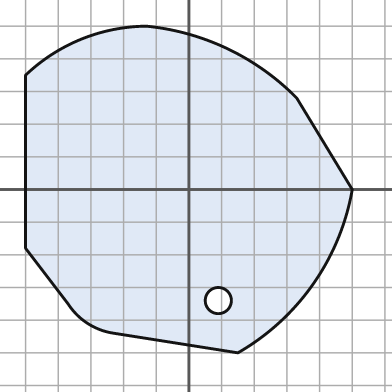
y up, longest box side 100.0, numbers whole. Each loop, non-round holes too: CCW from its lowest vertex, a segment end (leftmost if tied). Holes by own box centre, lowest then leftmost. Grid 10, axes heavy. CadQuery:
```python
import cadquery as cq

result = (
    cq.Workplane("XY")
    .moveTo(15.0, -50.0)
    .threePointArc((38.0, -29.0), (50.0, 0.0))
    .lineTo(33.0, 28.0)
    .threePointArc((12.0, 43.0), (-13.0, 50.0))
    .threePointArc((-33.0, 46.0), (-50.0, 35.0))
    .lineTo(-50.0, -18.0)
    .lineTo(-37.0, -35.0)
    .threePointArc((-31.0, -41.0), (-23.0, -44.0))
    .close()
    .moveTo(9.0, -34.0)
    .circle(4.0)
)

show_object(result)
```